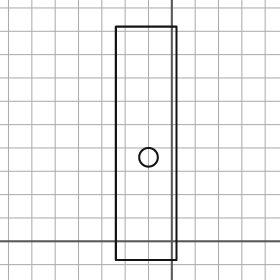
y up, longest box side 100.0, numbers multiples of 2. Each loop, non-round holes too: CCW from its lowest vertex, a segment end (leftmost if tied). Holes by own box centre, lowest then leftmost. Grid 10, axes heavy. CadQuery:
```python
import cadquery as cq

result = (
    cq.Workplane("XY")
    .moveTo(-24.0, -8.0)
    .lineTo(2.0, -8.0)
    .lineTo(2.0, 92.0)
    .lineTo(-24.0, 92.0)
    .close()
    .moveTo(-10.0, 36.0)
    .circle(4.0)
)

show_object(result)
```